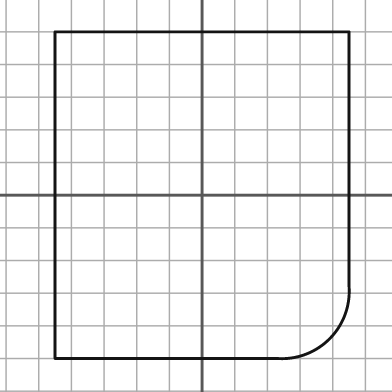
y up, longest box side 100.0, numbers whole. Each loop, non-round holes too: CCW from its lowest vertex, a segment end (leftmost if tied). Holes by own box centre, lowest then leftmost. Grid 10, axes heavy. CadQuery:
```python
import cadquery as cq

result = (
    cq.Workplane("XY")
    .moveTo(-45.0, -50.0)
    .lineTo(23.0, -50.0)
    .threePointArc((39.0, -44.0), (45.0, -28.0))
    .lineTo(45.0, 50.0)
    .lineTo(-45.0, 50.0)
    .close()
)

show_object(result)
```